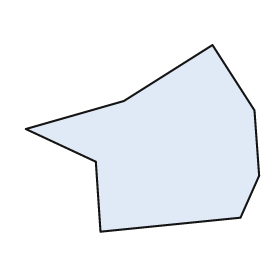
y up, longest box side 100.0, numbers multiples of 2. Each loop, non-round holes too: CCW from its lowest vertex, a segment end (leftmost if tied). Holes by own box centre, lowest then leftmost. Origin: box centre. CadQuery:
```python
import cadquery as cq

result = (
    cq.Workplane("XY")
    .moveTo(-18.0, -40.0)
    .lineTo(42.0, -34.0)
    .lineTo(50.0, -16.0)
    .lineTo(48.0, 12.0)
    .lineTo(30.0, 40.0)
    .lineTo(-8.0, 16.0)
    .lineTo(-50.0, 4.0)
    .lineTo(-20.0, -10.0)
    .close()
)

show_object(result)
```